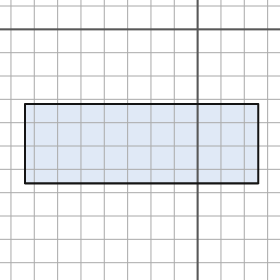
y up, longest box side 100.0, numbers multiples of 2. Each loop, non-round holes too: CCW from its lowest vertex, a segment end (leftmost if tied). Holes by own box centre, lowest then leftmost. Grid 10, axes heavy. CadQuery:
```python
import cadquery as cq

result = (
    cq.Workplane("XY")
    .moveTo(-74.0, -66.0)
    .lineTo(26.0, -66.0)
    .lineTo(26.0, -32.0)
    .lineTo(-74.0, -32.0)
    .close()
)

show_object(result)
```